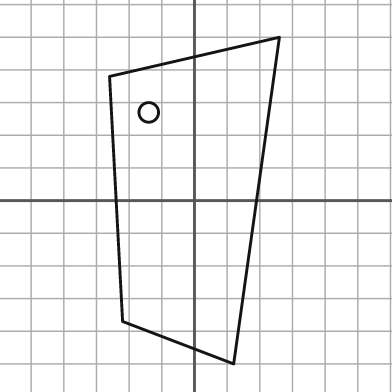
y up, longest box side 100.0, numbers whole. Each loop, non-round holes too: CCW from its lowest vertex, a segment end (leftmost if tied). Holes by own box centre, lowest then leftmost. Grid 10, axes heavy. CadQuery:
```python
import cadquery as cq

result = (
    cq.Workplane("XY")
    .moveTo(12.0, -50.0)
    .lineTo(26.0, 50.0)
    .lineTo(-26.0, 38.0)
    .lineTo(-22.0, -37.0)
    .close()
    .moveTo(-14.0, 27.0)
    .circle(3.0)
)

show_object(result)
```